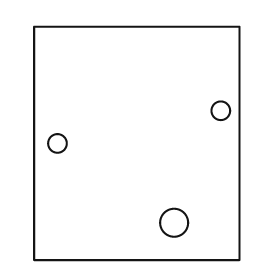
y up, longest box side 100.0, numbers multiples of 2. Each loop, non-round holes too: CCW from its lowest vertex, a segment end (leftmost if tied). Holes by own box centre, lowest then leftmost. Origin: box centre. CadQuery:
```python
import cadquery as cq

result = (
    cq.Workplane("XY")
    .moveTo(-44.0, -50.0)
    .lineTo(44.0, -50.0)
    .lineTo(44.0, 50.0)
    .lineTo(-44.0, 50.0)
    .close()
    .moveTo(16.0, -34.0)
    .circle(6.0)
    .moveTo(-34.0, 0.0)
    .circle(4.0)
    .moveTo(36.0, 14.0)
    .circle(4.0)
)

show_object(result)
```